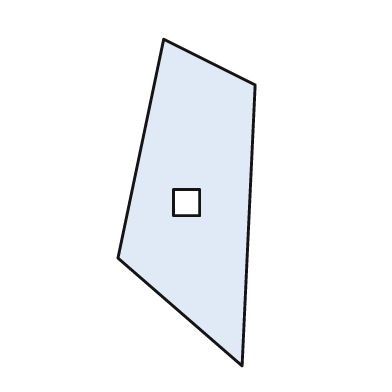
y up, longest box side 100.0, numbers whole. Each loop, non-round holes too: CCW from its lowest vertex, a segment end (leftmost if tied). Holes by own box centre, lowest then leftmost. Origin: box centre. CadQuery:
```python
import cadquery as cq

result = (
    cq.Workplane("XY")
    .moveTo(17.0, -50.0)
    .lineTo(21.0, 36.0)
    .lineTo(-7.0, 50.0)
    .lineTo(-21.0, -17.0)
    .close()
    .moveTo(-4.0, -4.0)
    .lineTo(4.0, -4.0)
    .lineTo(4.0, 4.0)
    .lineTo(-4.0, 4.0)
    .close()
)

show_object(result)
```